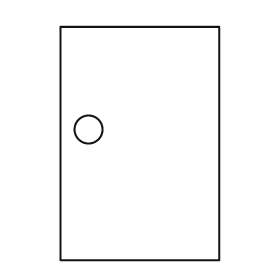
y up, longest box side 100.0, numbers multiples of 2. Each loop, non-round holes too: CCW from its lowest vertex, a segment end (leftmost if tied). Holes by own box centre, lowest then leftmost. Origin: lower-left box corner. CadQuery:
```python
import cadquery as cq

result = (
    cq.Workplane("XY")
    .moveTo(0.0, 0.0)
    .lineTo(68.0, 0.0)
    .lineTo(68.0, 100.0)
    .lineTo(0.0, 100.0)
    .close()
    .moveTo(12.0, 56.0)
    .circle(6.0)
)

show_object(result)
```